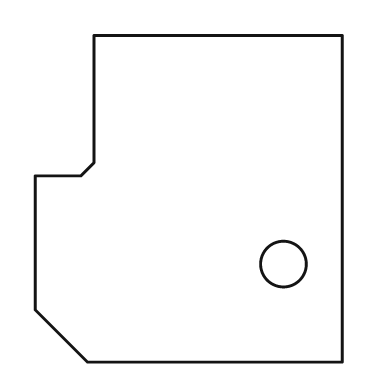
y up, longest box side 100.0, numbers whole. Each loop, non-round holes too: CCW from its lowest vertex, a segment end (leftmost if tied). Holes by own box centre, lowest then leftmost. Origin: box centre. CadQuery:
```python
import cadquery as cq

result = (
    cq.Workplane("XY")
    .moveTo(-31.0, -50.0)
    .lineTo(47.0, -50.0)
    .lineTo(47.0, 50.0)
    .lineTo(-29.0, 50.0)
    .lineTo(-29.0, 11.0)
    .lineTo(-33.0, 7.0)
    .lineTo(-47.0, 7.0)
    .lineTo(-47.0, -34.0)
    .close()
    .moveTo(29.0, -20.0)
    .circle(7.0)
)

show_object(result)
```